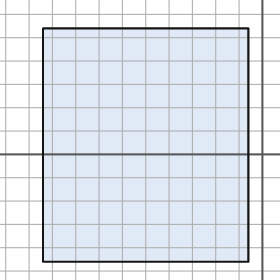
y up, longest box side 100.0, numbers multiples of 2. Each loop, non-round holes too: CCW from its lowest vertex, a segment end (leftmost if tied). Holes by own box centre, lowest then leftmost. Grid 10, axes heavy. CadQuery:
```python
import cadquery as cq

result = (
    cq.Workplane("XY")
    .moveTo(-94.0, -46.0)
    .lineTo(-6.0, -46.0)
    .lineTo(-6.0, 54.0)
    .lineTo(-94.0, 54.0)
    .close()
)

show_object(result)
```